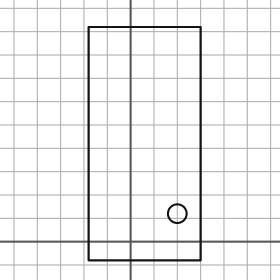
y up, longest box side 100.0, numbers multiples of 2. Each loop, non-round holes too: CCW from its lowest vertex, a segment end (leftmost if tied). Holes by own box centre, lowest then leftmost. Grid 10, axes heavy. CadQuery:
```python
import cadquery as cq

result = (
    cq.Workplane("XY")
    .moveTo(-18.0, -8.0)
    .lineTo(30.0, -8.0)
    .lineTo(30.0, 92.0)
    .lineTo(-18.0, 92.0)
    .close()
    .moveTo(20.0, 12.0)
    .circle(4.0)
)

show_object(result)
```